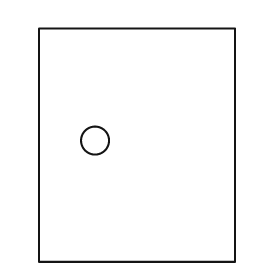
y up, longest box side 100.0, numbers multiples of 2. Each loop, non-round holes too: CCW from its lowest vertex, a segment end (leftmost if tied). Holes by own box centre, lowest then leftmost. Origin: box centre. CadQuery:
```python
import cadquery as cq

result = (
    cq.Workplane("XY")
    .moveTo(-42.0, -50.0)
    .lineTo(42.0, -50.0)
    .lineTo(42.0, 50.0)
    .lineTo(-42.0, 50.0)
    .close()
    .moveTo(-18.0, 2.0)
    .circle(6.0)
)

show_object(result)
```